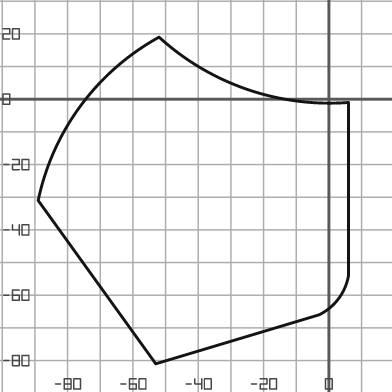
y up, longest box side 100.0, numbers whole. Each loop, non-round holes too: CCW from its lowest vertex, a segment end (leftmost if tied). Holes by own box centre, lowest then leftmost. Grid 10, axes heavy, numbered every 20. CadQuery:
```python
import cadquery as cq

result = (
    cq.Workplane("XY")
    .moveTo(-53.0, -81.0)
    .lineTo(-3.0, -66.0)
    .threePointArc((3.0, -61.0), (6.0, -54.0))
    .lineTo(6.0, -1.0)
    .threePointArc((-25.0, 3.0), (-52.0, 19.0))
    .threePointArc((-76.0, -2.0), (-89.0, -31.0))
    .close()
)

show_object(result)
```